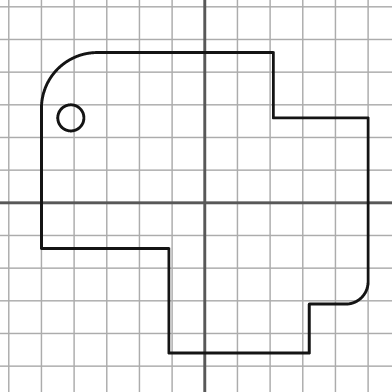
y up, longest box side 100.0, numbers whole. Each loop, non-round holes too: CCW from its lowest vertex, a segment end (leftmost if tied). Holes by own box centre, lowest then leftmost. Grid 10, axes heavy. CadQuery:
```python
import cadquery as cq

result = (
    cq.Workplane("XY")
    .moveTo(-11.0, -46.0)
    .lineTo(32.0, -46.0)
    .lineTo(32.0, -31.0)
    .lineTo(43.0, -31.0)
    .threePointArc((48.0, -29.0), (50.0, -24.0))
    .lineTo(50.0, 26.0)
    .lineTo(21.0, 26.0)
    .lineTo(21.0, 46.0)
    .lineTo(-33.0, 46.0)
    .threePointArc((-45.0, 41.0), (-50.0, 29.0))
    .lineTo(-50.0, -14.0)
    .lineTo(-11.0, -14.0)
    .close()
    .moveTo(-41.0, 26.0)
    .circle(4.0)
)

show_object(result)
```